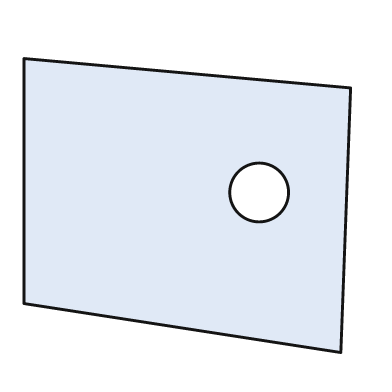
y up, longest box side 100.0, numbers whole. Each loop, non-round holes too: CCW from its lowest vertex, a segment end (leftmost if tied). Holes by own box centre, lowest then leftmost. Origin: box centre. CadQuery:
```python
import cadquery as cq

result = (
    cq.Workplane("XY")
    .moveTo(47.0, -45.0)
    .lineTo(50.0, 36.0)
    .lineTo(-50.0, 45.0)
    .lineTo(-50.0, -30.0)
    .close()
    .moveTo(22.0, 4.0)
    .circle(9.0)
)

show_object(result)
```